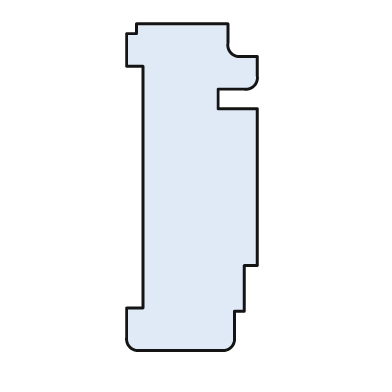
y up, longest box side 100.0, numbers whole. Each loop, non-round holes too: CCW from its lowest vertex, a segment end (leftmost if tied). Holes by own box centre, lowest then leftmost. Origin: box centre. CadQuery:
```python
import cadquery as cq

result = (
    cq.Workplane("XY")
    .moveTo(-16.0, -50.0)
    .lineTo(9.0, -50.0)
    .threePointArc((12.0, -49.0), (13.0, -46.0))
    .lineTo(13.0, -38.0)
    .lineTo(16.0, -38.0)
    .lineTo(16.0, -24.0)
    .lineTo(20.0, -24.0)
    .lineTo(20.0, 24.0)
    .lineTo(8.0, 24.0)
    .lineTo(8.0, 30.0)
    .lineTo(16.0, 30.0)
    .threePointArc((19.0, 31.0), (20.0, 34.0))
    .lineTo(20.0, 40.0)
    .lineTo(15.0, 40.0)
    .threePointArc((12.0, 41.0), (11.0, 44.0))
    .lineTo(11.0, 50.0)
    .lineTo(-17.0, 50.0)
    .lineTo(-17.0, 47.0)
    .lineTo(-20.0, 47.0)
    .lineTo(-20.0, 37.0)
    .lineTo(-15.0, 37.0)
    .lineTo(-15.0, -37.0)
    .lineTo(-20.0, -37.0)
    .lineTo(-20.0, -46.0)
    .threePointArc((-19.0, -49.0), (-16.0, -50.0))
    .close()
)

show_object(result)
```